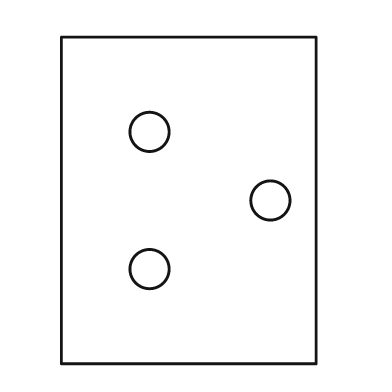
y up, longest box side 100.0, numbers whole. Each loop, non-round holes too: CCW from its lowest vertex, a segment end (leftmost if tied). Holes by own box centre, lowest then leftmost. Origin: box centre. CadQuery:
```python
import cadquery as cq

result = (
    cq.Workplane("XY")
    .moveTo(-39.0, -50.0)
    .lineTo(39.0, -50.0)
    .lineTo(39.0, 50.0)
    .lineTo(-39.0, 50.0)
    .close()
    .moveTo(-12.0, -21.0)
    .circle(6.0)
    .moveTo(25.0, 0.0)
    .circle(6.0)
    .moveTo(-12.0, 21.0)
    .circle(6.0)
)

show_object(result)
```